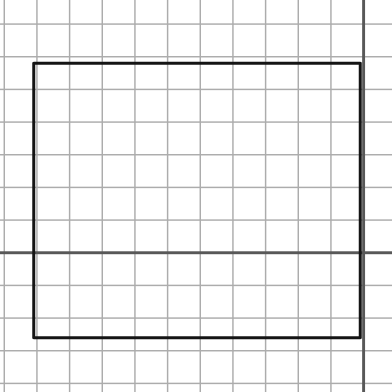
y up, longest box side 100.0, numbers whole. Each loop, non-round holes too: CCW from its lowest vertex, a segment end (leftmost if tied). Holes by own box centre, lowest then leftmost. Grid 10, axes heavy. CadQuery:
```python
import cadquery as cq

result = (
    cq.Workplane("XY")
    .moveTo(-101.0, -26.0)
    .lineTo(-1.0, -26.0)
    .lineTo(-1.0, 58.0)
    .lineTo(-101.0, 58.0)
    .close()
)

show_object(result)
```